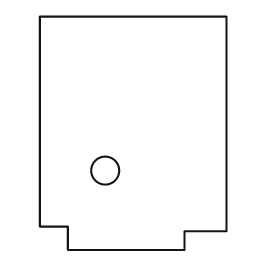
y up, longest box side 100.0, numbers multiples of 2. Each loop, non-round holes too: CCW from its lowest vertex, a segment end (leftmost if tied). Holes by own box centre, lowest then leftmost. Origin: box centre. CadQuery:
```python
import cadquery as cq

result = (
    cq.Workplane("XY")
    .moveTo(-28.0, -50.0)
    .lineTo(22.0, -50.0)
    .lineTo(22.0, -42.0)
    .lineTo(40.0, -42.0)
    .lineTo(40.0, 50.0)
    .lineTo(-40.0, 50.0)
    .lineTo(-40.0, -40.0)
    .lineTo(-28.0, -40.0)
    .close()
    .moveTo(-12.0, -16.0)
    .circle(6.0)
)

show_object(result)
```